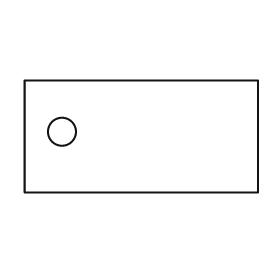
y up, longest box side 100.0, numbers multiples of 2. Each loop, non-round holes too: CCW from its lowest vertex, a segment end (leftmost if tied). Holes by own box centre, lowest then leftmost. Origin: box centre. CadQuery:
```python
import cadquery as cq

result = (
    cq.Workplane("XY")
    .moveTo(-50.0, -24.0)
    .lineTo(50.0, -24.0)
    .lineTo(50.0, 24.0)
    .lineTo(-50.0, 24.0)
    .close()
    .moveTo(-34.0, 2.0)
    .circle(6.0)
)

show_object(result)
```